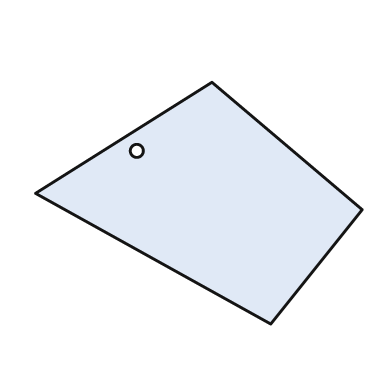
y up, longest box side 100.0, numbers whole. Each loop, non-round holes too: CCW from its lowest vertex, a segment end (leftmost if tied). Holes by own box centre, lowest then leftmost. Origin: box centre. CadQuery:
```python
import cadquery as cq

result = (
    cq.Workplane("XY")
    .moveTo(22.0, -37.0)
    .lineTo(50.0, -2.0)
    .lineTo(4.0, 37.0)
    .lineTo(-50.0, 3.0)
    .close()
    .moveTo(-19.0, 16.0)
    .circle(2.0)
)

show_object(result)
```